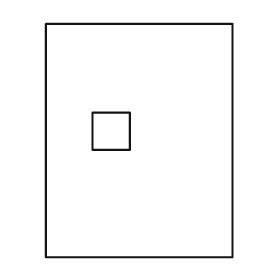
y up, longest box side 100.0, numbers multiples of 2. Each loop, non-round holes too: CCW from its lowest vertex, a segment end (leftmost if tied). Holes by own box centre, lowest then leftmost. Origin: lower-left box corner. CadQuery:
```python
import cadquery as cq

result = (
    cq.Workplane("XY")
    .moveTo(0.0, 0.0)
    .lineTo(80.0, 0.0)
    .lineTo(80.0, 100.0)
    .lineTo(0.0, 100.0)
    .close()
    .moveTo(20.0, 46.0)
    .lineTo(36.0, 46.0)
    .lineTo(36.0, 62.0)
    .lineTo(20.0, 62.0)
    .close()
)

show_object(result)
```